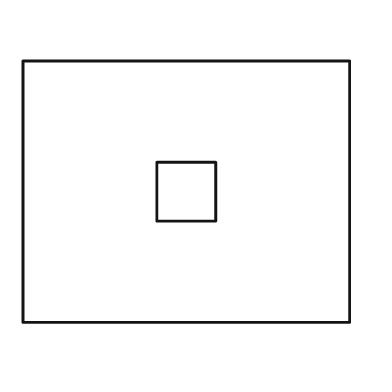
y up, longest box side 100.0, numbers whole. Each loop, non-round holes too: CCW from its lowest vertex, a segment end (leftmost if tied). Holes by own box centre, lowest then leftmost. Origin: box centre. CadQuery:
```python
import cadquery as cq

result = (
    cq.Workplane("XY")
    .moveTo(-50.0, -40.0)
    .lineTo(50.0, -40.0)
    .lineTo(50.0, 40.0)
    .lineTo(-50.0, 40.0)
    .close()
    .moveTo(-9.0, -9.0)
    .lineTo(9.0, -9.0)
    .lineTo(9.0, 9.0)
    .lineTo(-9.0, 9.0)
    .close()
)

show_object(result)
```